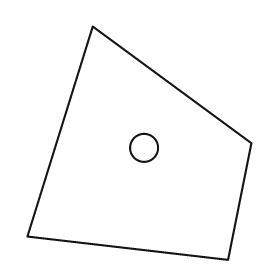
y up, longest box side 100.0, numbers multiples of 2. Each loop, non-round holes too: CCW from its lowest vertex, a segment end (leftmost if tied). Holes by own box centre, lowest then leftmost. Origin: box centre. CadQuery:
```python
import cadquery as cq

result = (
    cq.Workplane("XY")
    .moveTo(38.0, -50.0)
    .lineTo(48.0, 0.0)
    .lineTo(-20.0, 50.0)
    .lineTo(-48.0, -40.0)
    .close()
    .moveTo(2.0, -2.0)
    .circle(6.0)
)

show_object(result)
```